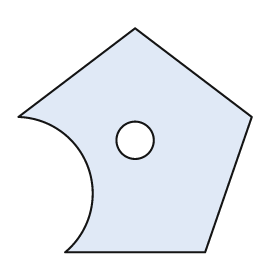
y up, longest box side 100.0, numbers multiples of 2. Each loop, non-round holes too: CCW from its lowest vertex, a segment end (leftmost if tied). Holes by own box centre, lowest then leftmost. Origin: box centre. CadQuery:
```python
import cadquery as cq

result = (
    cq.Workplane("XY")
    .moveTo(-30.0, -48.0)
    .lineTo(30.0, -48.0)
    .lineTo(50.0, 10.0)
    .lineTo(0.0, 48.0)
    .lineTo(-50.0, 10.0)
    .threePointArc((-20.0, -12.0), (-30.0, -48.0))
    .close()
    .moveTo(0.0, 0.0)
    .circle(8.0)
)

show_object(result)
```